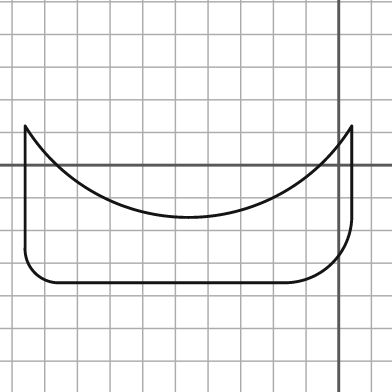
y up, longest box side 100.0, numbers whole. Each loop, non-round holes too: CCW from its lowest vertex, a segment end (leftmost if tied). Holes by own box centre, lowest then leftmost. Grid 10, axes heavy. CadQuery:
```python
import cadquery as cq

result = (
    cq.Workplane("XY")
    .moveTo(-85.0, -36.0)
    .lineTo(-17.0, -36.0)
    .threePointArc((-2.0, -30.0), (4.0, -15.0))
    .lineTo(4.0, 12.0)
    .threePointArc((-46.0, -16.0), (-96.0, 12.0))
    .lineTo(-96.0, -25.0)
    .threePointArc((-93.0, -33.0), (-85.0, -36.0))
    .close()
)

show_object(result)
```